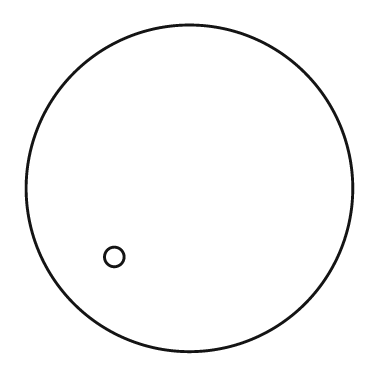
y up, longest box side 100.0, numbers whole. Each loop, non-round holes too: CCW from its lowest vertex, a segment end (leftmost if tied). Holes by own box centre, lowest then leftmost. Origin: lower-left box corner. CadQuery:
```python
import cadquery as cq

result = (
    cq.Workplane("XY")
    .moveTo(50.0, 50.0)
    .circle(50.0)
    .moveTo(27.0, 29.0)
    .circle(3.0)
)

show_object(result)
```